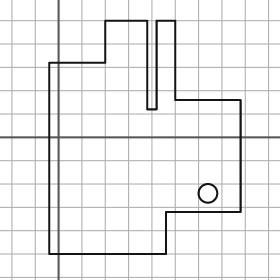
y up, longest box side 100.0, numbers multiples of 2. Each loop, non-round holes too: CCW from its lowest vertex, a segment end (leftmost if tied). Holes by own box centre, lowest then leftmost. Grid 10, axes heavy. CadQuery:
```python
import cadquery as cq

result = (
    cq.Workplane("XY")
    .moveTo(-4.0, -50.0)
    .lineTo(46.0, -50.0)
    .lineTo(46.0, -32.0)
    .lineTo(78.0, -32.0)
    .lineTo(78.0, 16.0)
    .lineTo(50.0, 16.0)
    .lineTo(50.0, 50.0)
    .lineTo(42.0, 50.0)
    .lineTo(42.0, 12.0)
    .lineTo(38.0, 12.0)
    .lineTo(38.0, 50.0)
    .lineTo(20.0, 50.0)
    .lineTo(20.0, 32.0)
    .lineTo(-4.0, 32.0)
    .close()
    .moveTo(64.0, -24.0)
    .circle(4.0)
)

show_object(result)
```